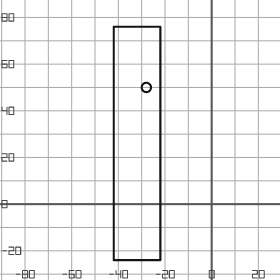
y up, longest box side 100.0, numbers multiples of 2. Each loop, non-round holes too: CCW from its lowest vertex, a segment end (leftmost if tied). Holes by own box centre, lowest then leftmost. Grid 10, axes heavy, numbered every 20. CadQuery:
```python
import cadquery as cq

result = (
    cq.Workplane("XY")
    .moveTo(-42.0, -24.0)
    .lineTo(-22.0, -24.0)
    .lineTo(-22.0, 76.0)
    .lineTo(-42.0, 76.0)
    .close()
    .moveTo(-28.0, 50.0)
    .circle(2.0)
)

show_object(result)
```